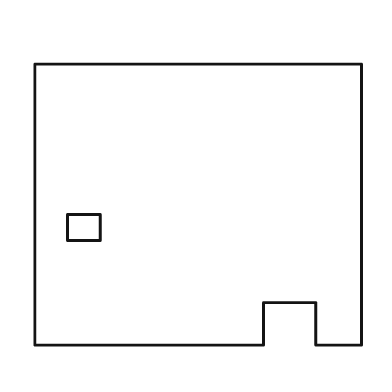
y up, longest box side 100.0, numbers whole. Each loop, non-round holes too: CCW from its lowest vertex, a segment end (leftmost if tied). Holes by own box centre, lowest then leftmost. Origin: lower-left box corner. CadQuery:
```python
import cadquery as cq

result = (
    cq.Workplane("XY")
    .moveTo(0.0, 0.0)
    .lineTo(70.0, 0.0)
    .lineTo(70.0, 13.0)
    .lineTo(86.0, 13.0)
    .lineTo(86.0, 0.0)
    .lineTo(100.0, 0.0)
    .lineTo(100.0, 86.0)
    .lineTo(0.0, 86.0)
    .close()
    .moveTo(10.0, 32.0)
    .lineTo(20.0, 32.0)
    .lineTo(20.0, 40.0)
    .lineTo(10.0, 40.0)
    .close()
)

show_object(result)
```